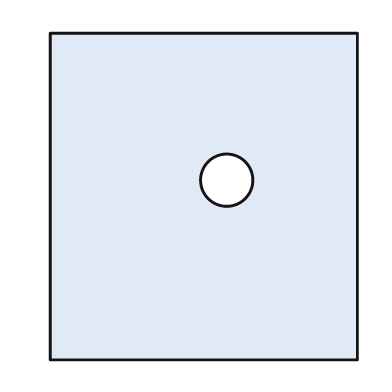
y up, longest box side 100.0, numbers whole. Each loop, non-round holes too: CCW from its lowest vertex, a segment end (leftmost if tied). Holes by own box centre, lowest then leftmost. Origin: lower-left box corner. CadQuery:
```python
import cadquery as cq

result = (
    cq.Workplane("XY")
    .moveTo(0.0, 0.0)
    .lineTo(94.0, 0.0)
    .lineTo(94.0, 100.0)
    .lineTo(0.0, 100.0)
    .close()
    .moveTo(54.0, 55.0)
    .circle(8.0)
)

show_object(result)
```